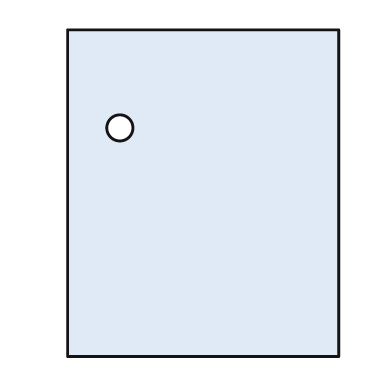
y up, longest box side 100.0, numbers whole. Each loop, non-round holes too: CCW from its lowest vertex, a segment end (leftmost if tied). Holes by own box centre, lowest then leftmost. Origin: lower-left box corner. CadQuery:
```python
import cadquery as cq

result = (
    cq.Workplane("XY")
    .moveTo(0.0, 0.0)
    .lineTo(83.0, 0.0)
    .lineTo(83.0, 100.0)
    .lineTo(0.0, 100.0)
    .close()
    .moveTo(16.0, 70.0)
    .circle(4.0)
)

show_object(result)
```